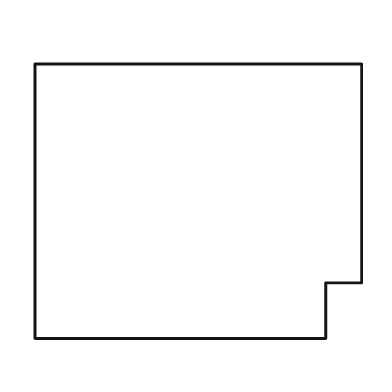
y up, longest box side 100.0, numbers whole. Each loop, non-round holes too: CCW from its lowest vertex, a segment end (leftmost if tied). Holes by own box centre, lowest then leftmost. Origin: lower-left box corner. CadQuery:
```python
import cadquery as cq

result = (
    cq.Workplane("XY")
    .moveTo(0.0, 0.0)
    .lineTo(89.0, 0.0)
    .lineTo(89.0, 17.0)
    .lineTo(100.0, 17.0)
    .lineTo(100.0, 84.0)
    .lineTo(0.0, 84.0)
    .close()
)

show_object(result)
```